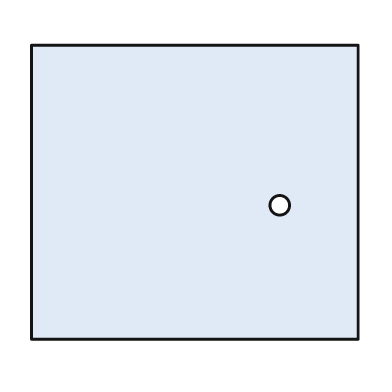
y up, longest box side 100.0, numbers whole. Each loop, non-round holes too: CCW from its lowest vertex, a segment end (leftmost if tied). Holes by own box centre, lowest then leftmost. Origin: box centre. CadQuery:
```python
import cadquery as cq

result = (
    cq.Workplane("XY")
    .moveTo(-50.0, -45.0)
    .lineTo(50.0, -45.0)
    .lineTo(50.0, 45.0)
    .lineTo(-50.0, 45.0)
    .close()
    .moveTo(26.0, -4.0)
    .circle(3.0)
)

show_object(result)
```